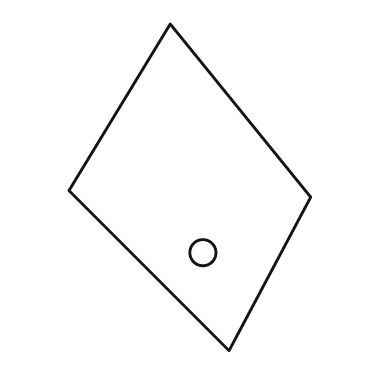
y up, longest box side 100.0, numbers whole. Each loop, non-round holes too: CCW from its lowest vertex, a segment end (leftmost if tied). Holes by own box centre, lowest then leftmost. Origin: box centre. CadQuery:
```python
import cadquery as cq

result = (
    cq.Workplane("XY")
    .moveTo(12.0, -50.0)
    .lineTo(37.0, -3.0)
    .lineTo(-6.0, 50.0)
    .lineTo(-37.0, -1.0)
    .close()
    .moveTo(4.0, -20.0)
    .circle(4.0)
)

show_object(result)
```